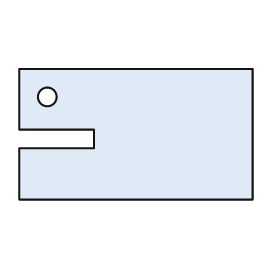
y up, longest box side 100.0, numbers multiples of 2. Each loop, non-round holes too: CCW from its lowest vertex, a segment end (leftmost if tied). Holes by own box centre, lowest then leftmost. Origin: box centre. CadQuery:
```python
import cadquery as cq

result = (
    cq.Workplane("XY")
    .moveTo(-50.0, -28.0)
    .lineTo(50.0, -28.0)
    .lineTo(50.0, 28.0)
    .lineTo(-50.0, 28.0)
    .lineTo(-50.0, 2.0)
    .lineTo(-18.0, 2.0)
    .lineTo(-18.0, -6.0)
    .lineTo(-50.0, -6.0)
    .close()
    .moveTo(-38.0, 16.0)
    .circle(4.0)
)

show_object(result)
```